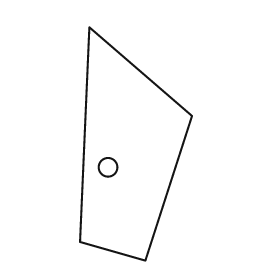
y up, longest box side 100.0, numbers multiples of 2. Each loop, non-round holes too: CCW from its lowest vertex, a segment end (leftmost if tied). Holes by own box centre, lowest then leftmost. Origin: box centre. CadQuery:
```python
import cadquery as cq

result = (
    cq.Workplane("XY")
    .moveTo(4.0, -50.0)
    .lineTo(24.0, 12.0)
    .lineTo(-20.0, 50.0)
    .lineTo(-24.0, -42.0)
    .close()
    .moveTo(-12.0, -10.0)
    .circle(4.0)
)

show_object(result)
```